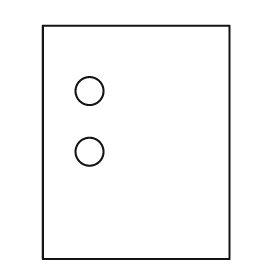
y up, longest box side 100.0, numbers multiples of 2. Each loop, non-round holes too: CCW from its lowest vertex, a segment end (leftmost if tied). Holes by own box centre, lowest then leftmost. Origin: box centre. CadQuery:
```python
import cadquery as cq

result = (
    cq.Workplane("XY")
    .moveTo(-40.0, -50.0)
    .lineTo(40.0, -50.0)
    .lineTo(40.0, 50.0)
    .lineTo(-40.0, 50.0)
    .close()
    .moveTo(-20.0, -4.0)
    .circle(6.0)
    .moveTo(-20.0, 22.0)
    .circle(6.0)
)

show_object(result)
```